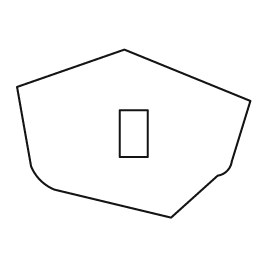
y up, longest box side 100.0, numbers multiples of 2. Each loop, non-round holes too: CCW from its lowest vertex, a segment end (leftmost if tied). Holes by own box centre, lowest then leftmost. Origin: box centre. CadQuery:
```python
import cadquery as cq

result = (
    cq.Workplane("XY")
    .moveTo(16.0, -36.0)
    .lineTo(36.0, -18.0)
    .threePointArc((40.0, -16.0), (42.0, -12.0))
    .lineTo(50.0, 14.0)
    .lineTo(-4.0, 36.0)
    .lineTo(-50.0, 20.0)
    .lineTo(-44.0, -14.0)
    .threePointArc((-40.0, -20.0), (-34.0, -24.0))
    .close()
    .moveTo(-6.0, -10.0)
    .lineTo(6.0, -10.0)
    .lineTo(6.0, 10.0)
    .lineTo(-6.0, 10.0)
    .close()
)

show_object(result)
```